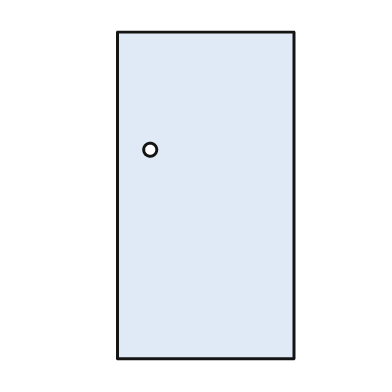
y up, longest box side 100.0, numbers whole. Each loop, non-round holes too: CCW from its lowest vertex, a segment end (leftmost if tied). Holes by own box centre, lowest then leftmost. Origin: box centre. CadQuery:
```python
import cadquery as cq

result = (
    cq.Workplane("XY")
    .moveTo(-27.0, -50.0)
    .lineTo(27.0, -50.0)
    .lineTo(27.0, 50.0)
    .lineTo(-27.0, 50.0)
    .close()
    .moveTo(-17.0, 14.0)
    .circle(2.0)
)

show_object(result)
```